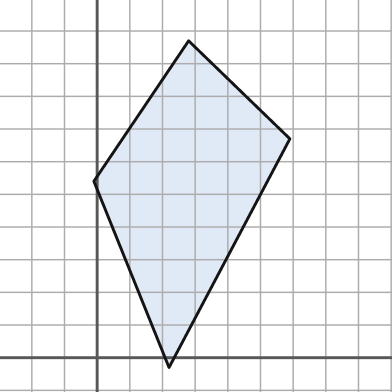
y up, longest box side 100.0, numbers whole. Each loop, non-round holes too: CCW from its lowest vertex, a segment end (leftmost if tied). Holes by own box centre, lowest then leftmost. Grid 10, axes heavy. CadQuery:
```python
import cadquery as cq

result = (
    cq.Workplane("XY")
    .moveTo(22.0, -3.0)
    .lineTo(59.0, 67.0)
    .lineTo(28.0, 97.0)
    .lineTo(-1.0, 54.0)
    .close()
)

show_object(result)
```